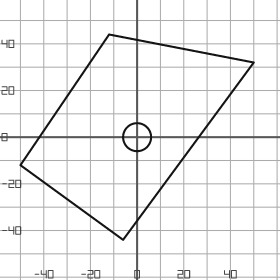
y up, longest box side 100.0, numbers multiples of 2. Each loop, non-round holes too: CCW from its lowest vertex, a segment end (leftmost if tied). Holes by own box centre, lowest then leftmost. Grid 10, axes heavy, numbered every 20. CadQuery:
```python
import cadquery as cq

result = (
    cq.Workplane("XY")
    .moveTo(-6.0, -44.0)
    .lineTo(50.0, 32.0)
    .lineTo(-12.0, 44.0)
    .lineTo(-50.0, -12.0)
    .close()
    .moveTo(0.0, 0.0)
    .circle(6.0)
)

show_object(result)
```